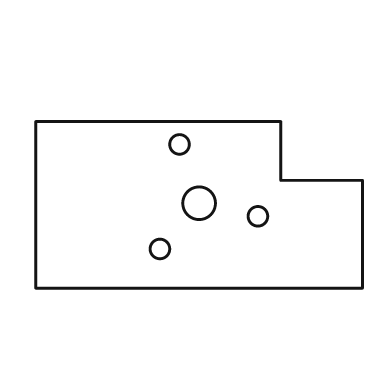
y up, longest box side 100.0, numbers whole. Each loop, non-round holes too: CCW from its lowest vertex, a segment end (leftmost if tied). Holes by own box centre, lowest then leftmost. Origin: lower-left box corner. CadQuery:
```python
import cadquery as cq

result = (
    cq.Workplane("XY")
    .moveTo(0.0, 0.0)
    .lineTo(100.0, 0.0)
    .lineTo(100.0, 33.0)
    .lineTo(75.0, 33.0)
    .lineTo(75.0, 51.0)
    .lineTo(0.0, 51.0)
    .close()
    .moveTo(38.0, 12.0)
    .circle(3.0)
    .moveTo(68.0, 22.0)
    .circle(3.0)
    .moveTo(50.0, 26.0)
    .circle(5.0)
    .moveTo(44.0, 44.0)
    .circle(3.0)
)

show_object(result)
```